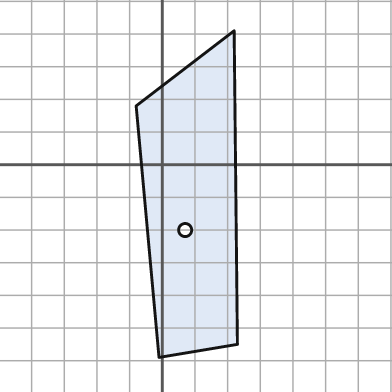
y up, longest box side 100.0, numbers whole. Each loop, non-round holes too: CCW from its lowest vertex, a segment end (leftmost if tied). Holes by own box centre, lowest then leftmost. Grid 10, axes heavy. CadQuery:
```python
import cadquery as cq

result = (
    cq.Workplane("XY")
    .moveTo(-1.0, -59.0)
    .lineTo(23.0, -55.0)
    .lineTo(22.0, 41.0)
    .lineTo(-8.0, 18.0)
    .close()
    .moveTo(7.0, -20.0)
    .circle(2.0)
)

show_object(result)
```